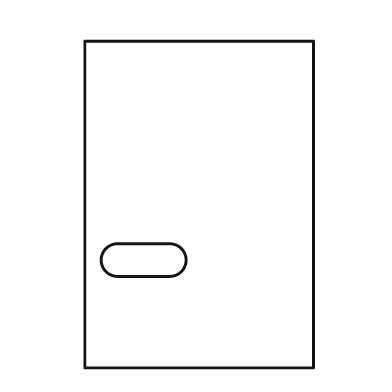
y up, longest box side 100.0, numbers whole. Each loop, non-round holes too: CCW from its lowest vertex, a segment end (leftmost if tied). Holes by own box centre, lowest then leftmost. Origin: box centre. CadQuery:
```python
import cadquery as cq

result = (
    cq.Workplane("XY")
    .moveTo(-35.0, -50.0)
    .lineTo(35.0, -50.0)
    .lineTo(35.0, 50.0)
    .lineTo(-35.0, 50.0)
    .close()
    .moveTo(-25.0, -22.0)
    .lineTo(-9.0, -22.0)
    .threePointArc((-4.0, -17.0), (-9.0, -12.0))
    .lineTo(-25.0, -12.0)
    .threePointArc((-30.0, -17.0), (-25.0, -22.0))
    .close()
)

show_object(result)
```